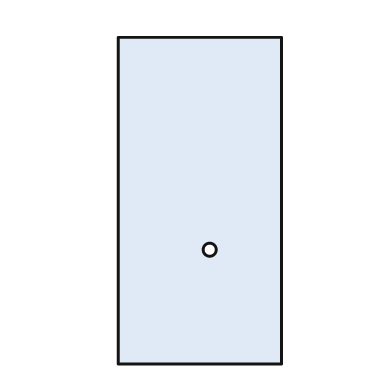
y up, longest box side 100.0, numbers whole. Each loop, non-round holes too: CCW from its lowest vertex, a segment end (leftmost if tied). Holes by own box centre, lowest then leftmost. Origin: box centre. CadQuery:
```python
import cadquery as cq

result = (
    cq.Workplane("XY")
    .moveTo(-25.0, -50.0)
    .lineTo(25.0, -50.0)
    .lineTo(25.0, 50.0)
    .lineTo(-25.0, 50.0)
    .close()
    .moveTo(3.0, -15.0)
    .circle(2.0)
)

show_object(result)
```